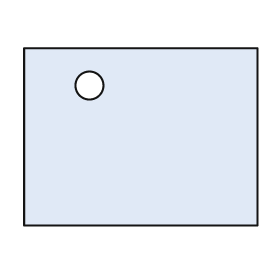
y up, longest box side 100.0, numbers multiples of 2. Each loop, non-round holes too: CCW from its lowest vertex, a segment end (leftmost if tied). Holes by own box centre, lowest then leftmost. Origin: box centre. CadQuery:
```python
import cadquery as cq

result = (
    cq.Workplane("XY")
    .moveTo(-50.0, -38.0)
    .lineTo(50.0, -38.0)
    .lineTo(50.0, 38.0)
    .lineTo(-50.0, 38.0)
    .close()
    .moveTo(-22.0, 22.0)
    .circle(6.0)
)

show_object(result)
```